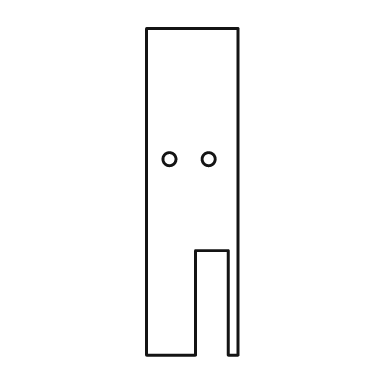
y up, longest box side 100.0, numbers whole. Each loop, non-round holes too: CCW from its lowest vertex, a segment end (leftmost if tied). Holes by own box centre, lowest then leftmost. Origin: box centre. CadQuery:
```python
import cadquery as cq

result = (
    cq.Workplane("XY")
    .moveTo(-14.0, -50.0)
    .lineTo(1.0, -50.0)
    .lineTo(1.0, -18.0)
    .lineTo(11.0, -18.0)
    .lineTo(11.0, -50.0)
    .lineTo(14.0, -50.0)
    .lineTo(14.0, 50.0)
    .lineTo(-14.0, 50.0)
    .close()
    .moveTo(-7.0, 10.0)
    .circle(2.0)
    .moveTo(5.0, 10.0)
    .circle(2.0)
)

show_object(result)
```